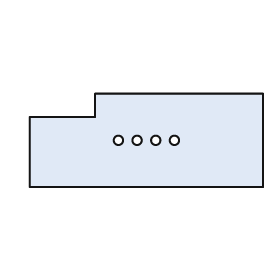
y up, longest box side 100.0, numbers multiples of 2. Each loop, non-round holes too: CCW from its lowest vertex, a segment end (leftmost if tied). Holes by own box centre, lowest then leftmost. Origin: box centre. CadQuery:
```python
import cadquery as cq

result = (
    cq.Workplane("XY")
    .moveTo(-50.0, -20.0)
    .lineTo(50.0, -20.0)
    .lineTo(50.0, 20.0)
    .lineTo(-22.0, 20.0)
    .lineTo(-22.0, 10.0)
    .lineTo(-50.0, 10.0)
    .close()
    .moveTo(-12.0, 0.0)
    .circle(2.0)
    .moveTo(-4.0, 0.0)
    .circle(2.0)
    .moveTo(4.0, 0.0)
    .circle(2.0)
    .moveTo(12.0, 0.0)
    .circle(2.0)
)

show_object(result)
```